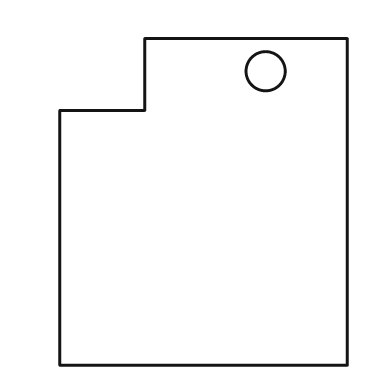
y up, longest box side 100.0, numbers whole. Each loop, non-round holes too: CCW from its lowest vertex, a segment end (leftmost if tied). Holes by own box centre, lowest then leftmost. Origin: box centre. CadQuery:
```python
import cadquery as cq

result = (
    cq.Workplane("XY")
    .moveTo(-44.0, -50.0)
    .lineTo(44.0, -50.0)
    .lineTo(44.0, 50.0)
    .lineTo(-18.0, 50.0)
    .lineTo(-18.0, 28.0)
    .lineTo(-44.0, 28.0)
    .close()
    .moveTo(19.0, 40.0)
    .circle(6.0)
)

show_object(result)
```